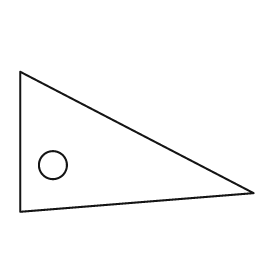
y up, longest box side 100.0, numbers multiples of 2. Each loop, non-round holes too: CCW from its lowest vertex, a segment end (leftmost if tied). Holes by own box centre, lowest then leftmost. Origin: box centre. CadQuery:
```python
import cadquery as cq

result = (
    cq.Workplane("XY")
    .moveTo(-50.0, -30.0)
    .lineTo(50.0, -22.0)
    .lineTo(-50.0, 30.0)
    .close()
    .moveTo(-36.0, -10.0)
    .circle(6.0)
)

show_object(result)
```